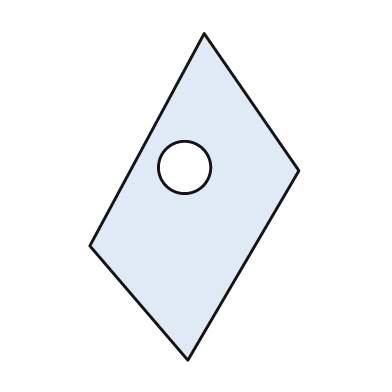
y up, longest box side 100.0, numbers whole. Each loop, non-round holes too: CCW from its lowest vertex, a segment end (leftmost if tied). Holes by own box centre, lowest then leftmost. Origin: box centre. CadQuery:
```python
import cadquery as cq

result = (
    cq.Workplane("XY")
    .moveTo(-2.0, -50.0)
    .lineTo(32.0, 8.0)
    .lineTo(3.0, 50.0)
    .lineTo(-32.0, -15.0)
    .close()
    .moveTo(-3.0, 9.0)
    .circle(8.0)
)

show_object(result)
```